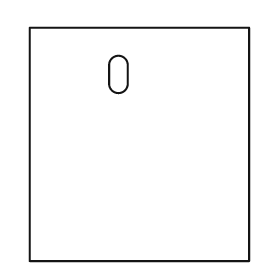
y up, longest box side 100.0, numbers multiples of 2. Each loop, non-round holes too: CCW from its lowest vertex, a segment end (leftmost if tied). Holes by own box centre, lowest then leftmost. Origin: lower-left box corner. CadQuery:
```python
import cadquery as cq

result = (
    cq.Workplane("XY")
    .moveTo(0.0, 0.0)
    .lineTo(94.0, 0.0)
    .lineTo(94.0, 100.0)
    .lineTo(0.0, 100.0)
    .close()
    .moveTo(34.0, 76.0)
    .threePointArc((38.0, 72.0), (42.0, 76.0))
    .lineTo(42.0, 84.0)
    .threePointArc((38.0, 88.0), (34.0, 84.0))
    .close()
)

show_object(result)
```